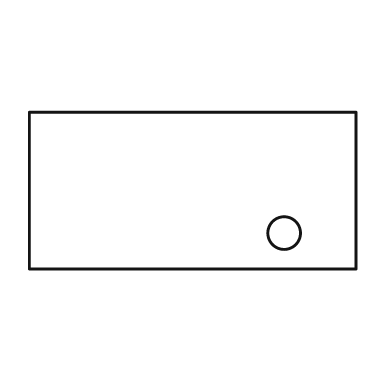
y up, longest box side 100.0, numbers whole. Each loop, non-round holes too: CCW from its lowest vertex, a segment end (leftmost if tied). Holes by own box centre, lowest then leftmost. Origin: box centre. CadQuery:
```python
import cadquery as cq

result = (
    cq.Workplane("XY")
    .moveTo(-50.0, -24.0)
    .lineTo(50.0, -24.0)
    .lineTo(50.0, 24.0)
    .lineTo(-50.0, 24.0)
    .close()
    .moveTo(28.0, -13.0)
    .circle(5.0)
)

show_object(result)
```